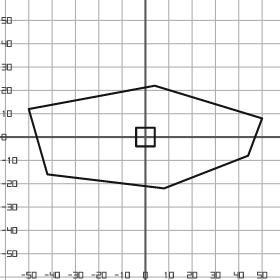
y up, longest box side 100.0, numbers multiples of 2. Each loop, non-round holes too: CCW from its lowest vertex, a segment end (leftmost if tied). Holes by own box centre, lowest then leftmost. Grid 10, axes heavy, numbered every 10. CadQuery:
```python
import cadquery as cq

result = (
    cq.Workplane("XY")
    .moveTo(8.0, -22.0)
    .lineTo(44.0, -8.0)
    .lineTo(50.0, 8.0)
    .lineTo(4.0, 22.0)
    .lineTo(-50.0, 12.0)
    .lineTo(-42.0, -16.0)
    .close()
    .moveTo(-4.0, -4.0)
    .lineTo(4.0, -4.0)
    .lineTo(4.0, 4.0)
    .lineTo(-4.0, 4.0)
    .close()
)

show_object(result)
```